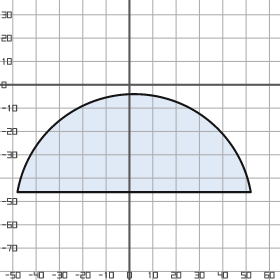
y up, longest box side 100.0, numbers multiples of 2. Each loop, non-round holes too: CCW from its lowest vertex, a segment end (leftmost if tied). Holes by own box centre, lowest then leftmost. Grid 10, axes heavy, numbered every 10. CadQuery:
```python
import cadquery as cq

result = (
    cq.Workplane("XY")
    .moveTo(-48.0, -46.0)
    .lineTo(52.0, -46.0)
    .threePointArc((2.0, -4.0), (-48.0, -46.0))
    .close()
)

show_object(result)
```